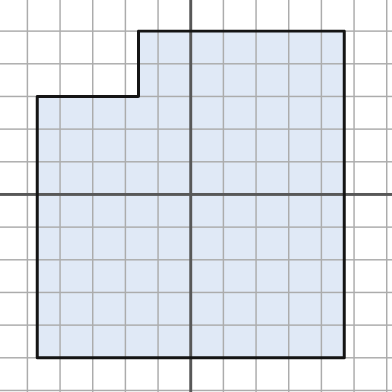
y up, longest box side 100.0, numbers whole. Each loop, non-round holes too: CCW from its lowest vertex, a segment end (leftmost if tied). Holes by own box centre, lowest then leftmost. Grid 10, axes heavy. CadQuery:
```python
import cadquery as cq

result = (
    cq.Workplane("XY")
    .moveTo(-47.0, -50.0)
    .lineTo(47.0, -50.0)
    .lineTo(47.0, 50.0)
    .lineTo(-16.0, 50.0)
    .lineTo(-16.0, 30.0)
    .lineTo(-47.0, 30.0)
    .close()
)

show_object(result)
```